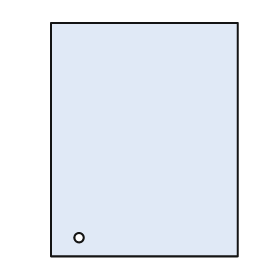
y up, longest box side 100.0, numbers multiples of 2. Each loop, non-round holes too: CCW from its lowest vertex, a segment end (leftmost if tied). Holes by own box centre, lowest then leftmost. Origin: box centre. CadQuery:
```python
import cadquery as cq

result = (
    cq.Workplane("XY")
    .moveTo(-40.0, -50.0)
    .lineTo(40.0, -50.0)
    .lineTo(40.0, 50.0)
    .lineTo(-40.0, 50.0)
    .close()
    .moveTo(-28.0, -42.0)
    .circle(2.0)
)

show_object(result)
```